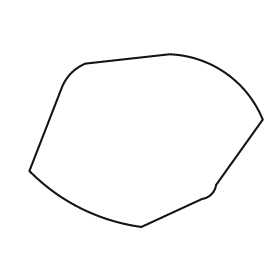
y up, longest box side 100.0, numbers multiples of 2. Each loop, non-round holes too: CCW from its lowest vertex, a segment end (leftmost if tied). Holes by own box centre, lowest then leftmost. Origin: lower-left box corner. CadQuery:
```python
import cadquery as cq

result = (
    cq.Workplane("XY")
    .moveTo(48.0, 0.0)
    .lineTo(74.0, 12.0)
    .threePointArc((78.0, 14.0), (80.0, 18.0))
    .lineTo(100.0, 46.0)
    .threePointArc((84.0, 66.0), (60.0, 74.0))
    .lineTo(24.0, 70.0)
    .threePointArc((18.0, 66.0), (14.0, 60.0))
    .lineTo(0.0, 24.0)
    .threePointArc((22.0, 8.0), (48.0, 0.0))
    .close()
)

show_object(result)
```